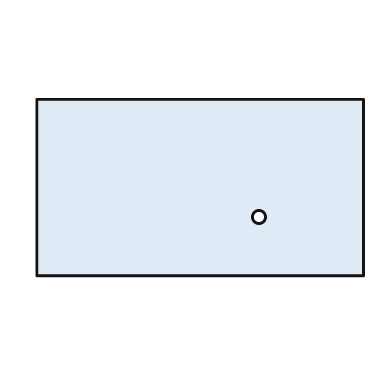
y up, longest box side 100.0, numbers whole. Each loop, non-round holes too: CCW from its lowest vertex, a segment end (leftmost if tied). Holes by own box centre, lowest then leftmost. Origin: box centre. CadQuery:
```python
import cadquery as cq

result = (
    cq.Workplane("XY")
    .moveTo(-50.0, -27.0)
    .lineTo(50.0, -27.0)
    .lineTo(50.0, 27.0)
    .lineTo(-50.0, 27.0)
    .close()
    .moveTo(18.0, -9.0)
    .circle(2.0)
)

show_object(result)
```